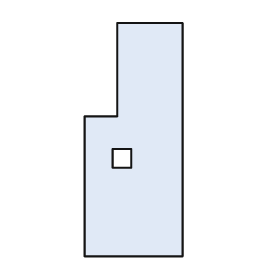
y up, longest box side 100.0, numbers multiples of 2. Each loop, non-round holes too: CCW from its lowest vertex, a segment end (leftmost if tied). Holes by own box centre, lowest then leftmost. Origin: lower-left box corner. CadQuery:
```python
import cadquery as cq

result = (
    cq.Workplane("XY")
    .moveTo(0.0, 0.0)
    .lineTo(42.0, 0.0)
    .lineTo(42.0, 100.0)
    .lineTo(14.0, 100.0)
    .lineTo(14.0, 60.0)
    .lineTo(0.0, 60.0)
    .close()
    .moveTo(12.0, 38.0)
    .lineTo(20.0, 38.0)
    .lineTo(20.0, 46.0)
    .lineTo(12.0, 46.0)
    .close()
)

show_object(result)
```